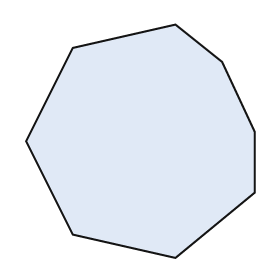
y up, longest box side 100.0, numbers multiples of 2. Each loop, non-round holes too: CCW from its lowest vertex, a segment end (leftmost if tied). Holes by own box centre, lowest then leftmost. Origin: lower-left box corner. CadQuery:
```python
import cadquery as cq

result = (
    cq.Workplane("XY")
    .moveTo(64.0, 0.0)
    .lineTo(98.0, 28.0)
    .lineTo(98.0, 54.0)
    .lineTo(84.0, 84.0)
    .lineTo(64.0, 100.0)
    .lineTo(20.0, 90.0)
    .lineTo(0.0, 50.0)
    .lineTo(20.0, 10.0)
    .close()
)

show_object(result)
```